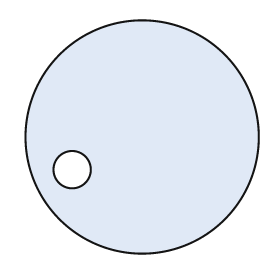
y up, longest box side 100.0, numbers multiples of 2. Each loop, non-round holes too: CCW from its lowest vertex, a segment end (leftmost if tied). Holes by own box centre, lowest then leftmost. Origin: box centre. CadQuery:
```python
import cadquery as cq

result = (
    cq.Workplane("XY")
    .moveTo(0.0, 0.0)
    .circle(50.0)
    .moveTo(-30.0, -14.0)
    .circle(8.0)
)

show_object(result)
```